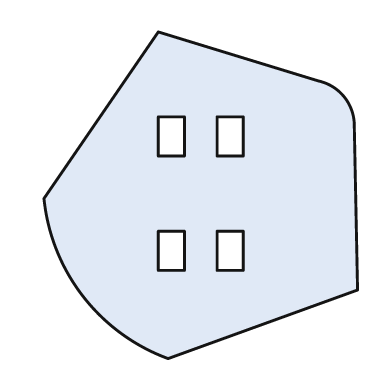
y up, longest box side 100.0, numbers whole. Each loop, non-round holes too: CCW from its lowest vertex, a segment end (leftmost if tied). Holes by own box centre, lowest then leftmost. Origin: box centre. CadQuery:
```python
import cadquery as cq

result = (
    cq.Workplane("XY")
    .moveTo(-10.0, -50.0)
    .lineTo(48.0, -29.0)
    .lineTo(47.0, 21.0)
    .threePointArc((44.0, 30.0), (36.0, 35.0))
    .lineTo(-13.0, 50.0)
    .lineTo(-48.0, -1.0)
    .threePointArc((-36.0, -31.0), (-10.0, -50.0))
    .close()
    .moveTo(-13.0, -23.0)
    .lineTo(-5.0, -23.0)
    .lineTo(-5.0, -11.0)
    .lineTo(-13.0, -11.0)
    .close()
    .moveTo(5.0, -23.0)
    .lineTo(13.0, -23.0)
    .lineTo(13.0, -11.0)
    .lineTo(5.0, -11.0)
    .close()
    .moveTo(-13.0, 12.0)
    .lineTo(-5.0, 12.0)
    .lineTo(-5.0, 24.0)
    .lineTo(-13.0, 24.0)
    .close()
    .moveTo(5.0, 12.0)
    .lineTo(13.0, 12.0)
    .lineTo(13.0, 24.0)
    .lineTo(5.0, 24.0)
    .close()
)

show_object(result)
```